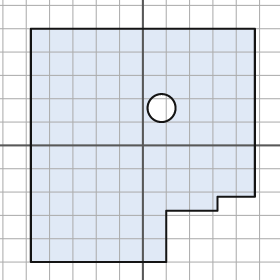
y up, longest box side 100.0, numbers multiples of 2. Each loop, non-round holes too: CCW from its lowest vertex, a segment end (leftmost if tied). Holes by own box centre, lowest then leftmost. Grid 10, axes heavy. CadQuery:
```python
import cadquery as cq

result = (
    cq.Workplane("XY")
    .moveTo(-48.0, -50.0)
    .lineTo(10.0, -50.0)
    .lineTo(10.0, -28.0)
    .lineTo(32.0, -28.0)
    .lineTo(32.0, -22.0)
    .lineTo(48.0, -22.0)
    .lineTo(48.0, 50.0)
    .lineTo(-48.0, 50.0)
    .close()
    .moveTo(8.0, 16.0)
    .circle(6.0)
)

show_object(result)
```